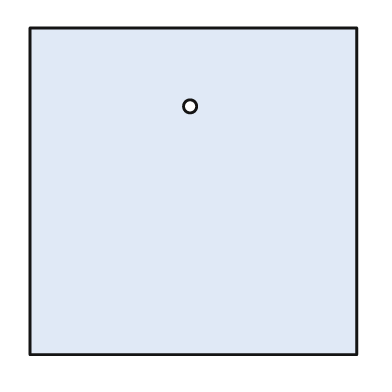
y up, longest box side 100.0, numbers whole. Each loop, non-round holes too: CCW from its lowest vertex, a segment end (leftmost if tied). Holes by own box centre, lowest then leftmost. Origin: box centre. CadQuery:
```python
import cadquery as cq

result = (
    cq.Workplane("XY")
    .moveTo(-50.0, -50.0)
    .lineTo(50.0, -50.0)
    .lineTo(50.0, 50.0)
    .lineTo(-50.0, 50.0)
    .close()
    .moveTo(-1.0, 26.0)
    .circle(2.0)
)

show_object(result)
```